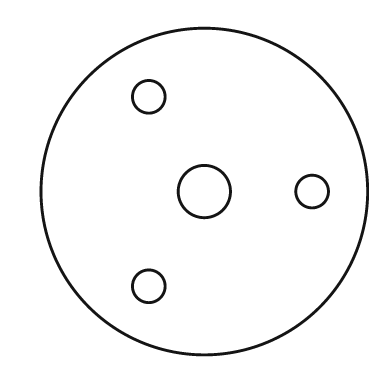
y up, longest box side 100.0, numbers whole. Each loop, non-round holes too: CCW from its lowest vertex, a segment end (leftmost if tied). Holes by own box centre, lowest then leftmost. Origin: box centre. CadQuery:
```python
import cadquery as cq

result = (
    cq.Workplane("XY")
    .moveTo(0.0, 0.0)
    .circle(50.0)
    .moveTo(-17.0, -29.0)
    .circle(5.0)
    .moveTo(0.0, 0.0)
    .circle(8.0)
    .moveTo(33.0, 0.0)
    .circle(5.0)
    .moveTo(-17.0, 29.0)
    .circle(5.0)
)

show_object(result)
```